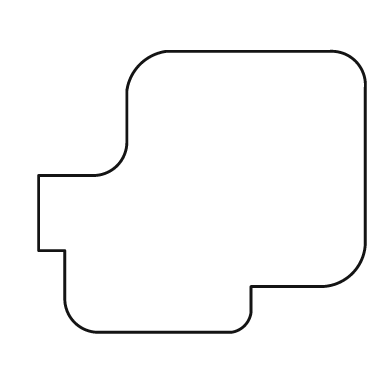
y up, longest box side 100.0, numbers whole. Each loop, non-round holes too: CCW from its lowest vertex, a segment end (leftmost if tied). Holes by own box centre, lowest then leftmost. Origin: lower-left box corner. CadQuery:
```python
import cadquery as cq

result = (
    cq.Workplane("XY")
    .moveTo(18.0, 0.0)
    .lineTo(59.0, 0.0)
    .threePointArc((63.0, 2.0), (65.0, 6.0))
    .lineTo(65.0, 14.0)
    .lineTo(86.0, 14.0)
    .threePointArc((96.0, 18.0), (100.0, 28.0))
    .lineTo(100.0, 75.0)
    .threePointArc((97.0, 83.0), (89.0, 86.0))
    .lineTo(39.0, 86.0)
    .threePointArc((31.0, 82.0), (27.0, 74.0))
    .lineTo(27.0, 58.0)
    .threePointArc((24.0, 51.0), (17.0, 48.0))
    .lineTo(0.0, 48.0)
    .lineTo(0.0, 25.0)
    .lineTo(8.0, 25.0)
    .lineTo(8.0, 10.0)
    .threePointArc((11.0, 3.0), (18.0, 0.0))
    .close()
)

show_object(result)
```